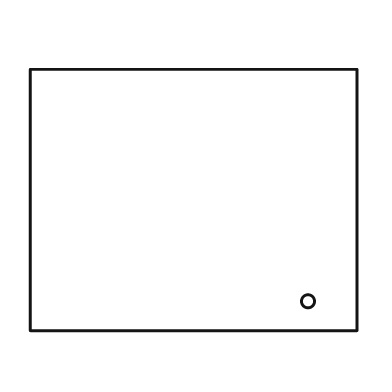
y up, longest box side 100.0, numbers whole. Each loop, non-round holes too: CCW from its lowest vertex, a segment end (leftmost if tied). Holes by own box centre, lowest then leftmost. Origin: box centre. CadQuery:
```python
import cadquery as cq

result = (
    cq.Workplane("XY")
    .moveTo(-50.0, -40.0)
    .lineTo(50.0, -40.0)
    .lineTo(50.0, 40.0)
    .lineTo(-50.0, 40.0)
    .close()
    .moveTo(35.0, -31.0)
    .circle(2.0)
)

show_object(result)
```